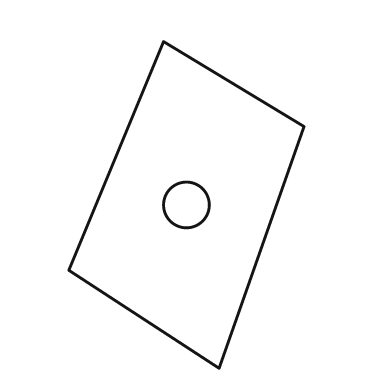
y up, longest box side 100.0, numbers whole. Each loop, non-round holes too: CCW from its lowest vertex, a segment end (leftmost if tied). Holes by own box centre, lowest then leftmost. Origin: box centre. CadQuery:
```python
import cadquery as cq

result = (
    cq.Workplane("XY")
    .moveTo(10.0, -50.0)
    .lineTo(36.0, 24.0)
    .lineTo(-7.0, 50.0)
    .lineTo(-36.0, -20.0)
    .close()
    .moveTo(0.0, 0.0)
    .circle(7.0)
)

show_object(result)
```